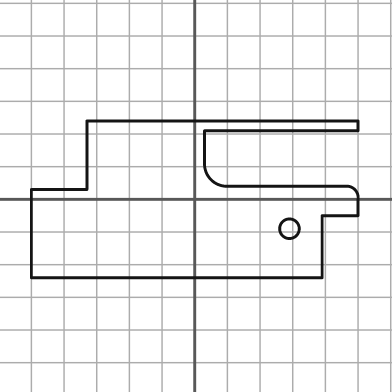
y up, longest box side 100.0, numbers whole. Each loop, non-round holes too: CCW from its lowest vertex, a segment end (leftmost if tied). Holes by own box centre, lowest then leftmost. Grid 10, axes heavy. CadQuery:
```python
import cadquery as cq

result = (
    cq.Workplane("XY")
    .moveTo(-50.0, -24.0)
    .lineTo(39.0, -24.0)
    .lineTo(39.0, -5.0)
    .lineTo(50.0, -5.0)
    .lineTo(50.0, 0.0)
    .threePointArc((49.0, 3.0), (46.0, 4.0))
    .lineTo(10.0, 4.0)
    .threePointArc((5.0, 6.0), (3.0, 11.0))
    .lineTo(3.0, 21.0)
    .lineTo(50.0, 21.0)
    .lineTo(50.0, 24.0)
    .lineTo(-33.0, 24.0)
    .lineTo(-33.0, 3.0)
    .lineTo(-50.0, 3.0)
    .close()
    .moveTo(29.0, -9.0)
    .circle(3.0)
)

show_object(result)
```